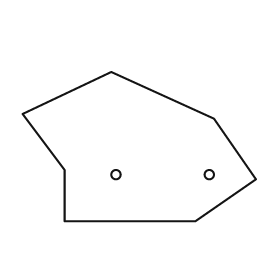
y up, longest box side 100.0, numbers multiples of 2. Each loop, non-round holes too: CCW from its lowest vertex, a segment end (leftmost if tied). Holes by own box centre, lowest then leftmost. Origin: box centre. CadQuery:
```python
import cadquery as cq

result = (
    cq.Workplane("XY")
    .moveTo(-32.0, -32.0)
    .lineTo(24.0, -32.0)
    .lineTo(50.0, -14.0)
    .lineTo(32.0, 12.0)
    .lineTo(-12.0, 32.0)
    .lineTo(-50.0, 14.0)
    .lineTo(-32.0, -10.0)
    .close()
    .moveTo(-10.0, -12.0)
    .circle(2.0)
    .moveTo(30.0, -12.0)
    .circle(2.0)
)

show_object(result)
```